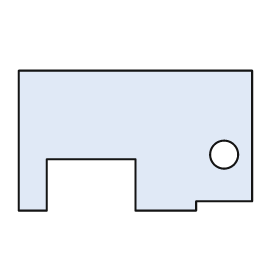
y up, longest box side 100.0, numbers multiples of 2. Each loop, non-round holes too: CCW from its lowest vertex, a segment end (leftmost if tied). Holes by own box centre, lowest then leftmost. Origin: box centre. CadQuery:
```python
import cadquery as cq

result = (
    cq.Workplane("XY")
    .moveTo(-50.0, -30.0)
    .lineTo(-38.0, -30.0)
    .lineTo(-38.0, -8.0)
    .lineTo(0.0, -8.0)
    .lineTo(0.0, -30.0)
    .lineTo(26.0, -30.0)
    .lineTo(26.0, -26.0)
    .lineTo(50.0, -26.0)
    .lineTo(50.0, 30.0)
    .lineTo(-50.0, 30.0)
    .close()
    .moveTo(38.0, -6.0)
    .circle(6.0)
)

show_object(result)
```